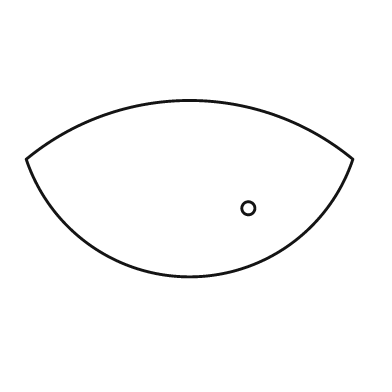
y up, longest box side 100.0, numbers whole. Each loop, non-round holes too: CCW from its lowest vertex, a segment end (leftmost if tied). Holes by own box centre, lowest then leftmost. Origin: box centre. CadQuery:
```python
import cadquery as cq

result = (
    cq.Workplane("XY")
    .moveTo(-50.0, 9.0)
    .threePointArc((0.0, -27.0), (50.0, 9.0))
    .threePointArc((0.0, 27.0), (-50.0, 9.0))
    .close()
    .moveTo(18.0, -6.0)
    .circle(2.0)
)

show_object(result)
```